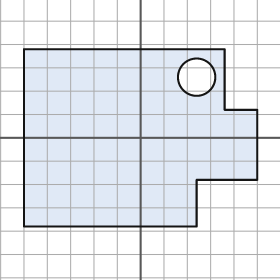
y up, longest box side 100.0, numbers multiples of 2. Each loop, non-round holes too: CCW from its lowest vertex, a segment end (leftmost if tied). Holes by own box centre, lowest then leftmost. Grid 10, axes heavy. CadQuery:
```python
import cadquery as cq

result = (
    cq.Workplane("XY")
    .moveTo(-50.0, -38.0)
    .lineTo(24.0, -38.0)
    .lineTo(24.0, -18.0)
    .lineTo(50.0, -18.0)
    .lineTo(50.0, 12.0)
    .lineTo(36.0, 12.0)
    .lineTo(36.0, 38.0)
    .lineTo(-50.0, 38.0)
    .close()
    .moveTo(24.0, 26.0)
    .circle(8.0)
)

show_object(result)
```